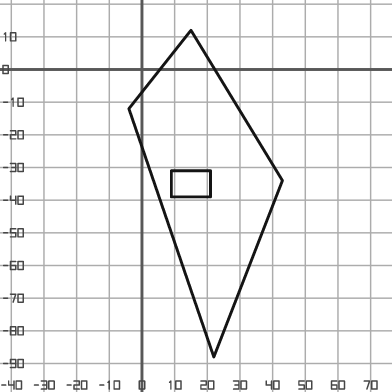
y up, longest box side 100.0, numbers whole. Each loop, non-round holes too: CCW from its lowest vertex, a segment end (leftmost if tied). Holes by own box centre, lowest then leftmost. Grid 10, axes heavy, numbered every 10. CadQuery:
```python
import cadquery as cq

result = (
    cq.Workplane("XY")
    .moveTo(22.0, -88.0)
    .lineTo(43.0, -34.0)
    .lineTo(15.0, 12.0)
    .lineTo(-4.0, -12.0)
    .close()
    .moveTo(9.0, -39.0)
    .lineTo(21.0, -39.0)
    .lineTo(21.0, -31.0)
    .lineTo(9.0, -31.0)
    .close()
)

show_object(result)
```